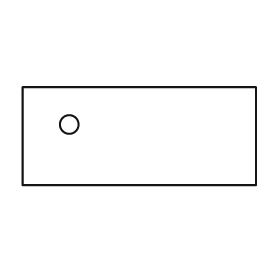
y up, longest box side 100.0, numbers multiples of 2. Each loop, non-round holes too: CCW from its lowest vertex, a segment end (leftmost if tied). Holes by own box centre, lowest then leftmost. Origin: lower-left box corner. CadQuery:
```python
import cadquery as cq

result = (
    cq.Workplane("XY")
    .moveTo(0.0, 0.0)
    .lineTo(100.0, 0.0)
    .lineTo(100.0, 42.0)
    .lineTo(0.0, 42.0)
    .close()
    .moveTo(20.0, 26.0)
    .circle(4.0)
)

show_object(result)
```